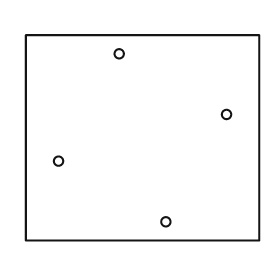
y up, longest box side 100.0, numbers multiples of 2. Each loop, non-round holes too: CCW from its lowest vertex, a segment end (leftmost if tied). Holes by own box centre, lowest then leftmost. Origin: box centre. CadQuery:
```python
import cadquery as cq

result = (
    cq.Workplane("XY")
    .moveTo(-50.0, -44.0)
    .lineTo(50.0, -44.0)
    .lineTo(50.0, 44.0)
    .lineTo(-50.0, 44.0)
    .close()
    .moveTo(10.0, -36.0)
    .circle(2.0)
    .moveTo(-36.0, -10.0)
    .circle(2.0)
    .moveTo(36.0, 10.0)
    .circle(2.0)
    .moveTo(-10.0, 36.0)
    .circle(2.0)
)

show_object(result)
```